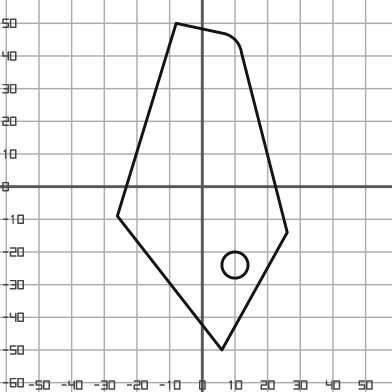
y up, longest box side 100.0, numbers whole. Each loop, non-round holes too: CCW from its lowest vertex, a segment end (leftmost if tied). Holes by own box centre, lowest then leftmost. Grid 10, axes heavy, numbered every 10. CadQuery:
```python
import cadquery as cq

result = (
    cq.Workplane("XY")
    .moveTo(6.0, -50.0)
    .lineTo(26.0, -14.0)
    .lineTo(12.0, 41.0)
    .threePointArc((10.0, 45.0), (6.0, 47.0))
    .lineTo(-8.0, 50.0)
    .lineTo(-26.0, -9.0)
    .close()
    .moveTo(10.0, -24.0)
    .circle(4.0)
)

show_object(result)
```